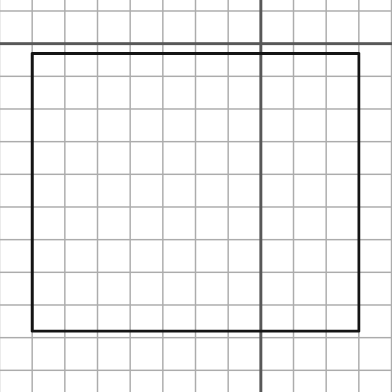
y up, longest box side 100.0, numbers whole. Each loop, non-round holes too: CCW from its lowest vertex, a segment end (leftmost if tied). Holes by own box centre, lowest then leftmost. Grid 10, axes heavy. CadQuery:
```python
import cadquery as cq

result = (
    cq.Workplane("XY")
    .moveTo(-70.0, -88.0)
    .lineTo(30.0, -88.0)
    .lineTo(30.0, -3.0)
    .lineTo(-70.0, -3.0)
    .close()
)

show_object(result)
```